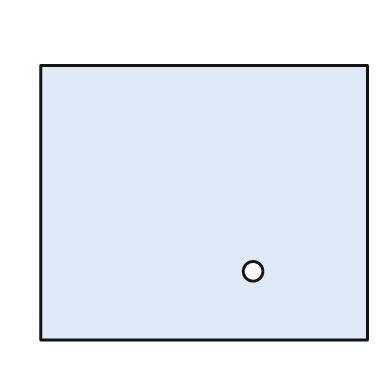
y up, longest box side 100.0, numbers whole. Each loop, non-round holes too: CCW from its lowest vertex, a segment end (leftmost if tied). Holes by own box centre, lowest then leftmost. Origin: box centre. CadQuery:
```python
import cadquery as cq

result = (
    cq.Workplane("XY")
    .moveTo(-50.0, -42.0)
    .lineTo(50.0, -42.0)
    .lineTo(50.0, 42.0)
    .lineTo(-50.0, 42.0)
    .close()
    .moveTo(15.0, -21.0)
    .circle(3.0)
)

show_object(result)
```